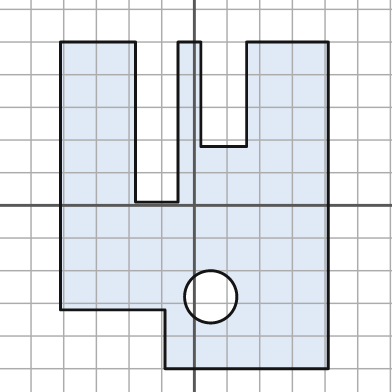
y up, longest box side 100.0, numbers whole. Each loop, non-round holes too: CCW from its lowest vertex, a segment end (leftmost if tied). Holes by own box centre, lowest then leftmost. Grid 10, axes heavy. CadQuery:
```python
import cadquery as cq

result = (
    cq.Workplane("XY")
    .moveTo(-9.0, -50.0)
    .lineTo(41.0, -50.0)
    .lineTo(41.0, 50.0)
    .lineTo(16.0, 50.0)
    .lineTo(16.0, 18.0)
    .lineTo(2.0, 18.0)
    .lineTo(2.0, 50.0)
    .lineTo(-5.0, 50.0)
    .lineTo(-5.0, 1.0)
    .lineTo(-18.0, 1.0)
    .lineTo(-18.0, 50.0)
    .lineTo(-41.0, 50.0)
    .lineTo(-41.0, -32.0)
    .lineTo(-9.0, -32.0)
    .close()
    .moveTo(5.0, -28.0)
    .circle(8.0)
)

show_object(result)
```